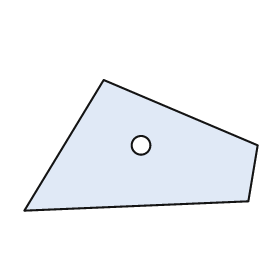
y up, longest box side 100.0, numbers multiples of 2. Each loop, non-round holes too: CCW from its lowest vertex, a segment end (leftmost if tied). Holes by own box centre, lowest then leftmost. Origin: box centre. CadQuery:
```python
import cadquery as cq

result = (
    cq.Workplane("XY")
    .moveTo(-50.0, -28.0)
    .lineTo(46.0, -24.0)
    .lineTo(50.0, 0.0)
    .lineTo(-16.0, 28.0)
    .close()
    .moveTo(0.0, 0.0)
    .circle(4.0)
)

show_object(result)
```